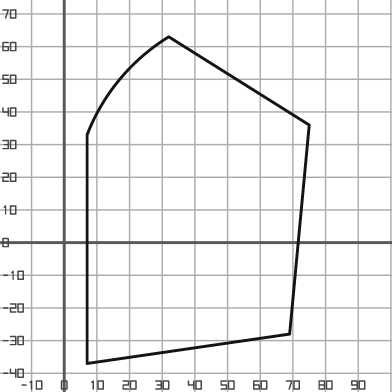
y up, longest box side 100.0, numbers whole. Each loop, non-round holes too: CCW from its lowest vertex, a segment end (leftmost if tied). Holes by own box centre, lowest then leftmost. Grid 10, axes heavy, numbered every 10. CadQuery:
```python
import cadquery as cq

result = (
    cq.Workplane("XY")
    .moveTo(7.0, -37.0)
    .lineTo(69.0, -28.0)
    .lineTo(75.0, 36.0)
    .lineTo(32.0, 63.0)
    .threePointArc((17.0, 50.0), (7.0, 33.0))
    .close()
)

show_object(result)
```